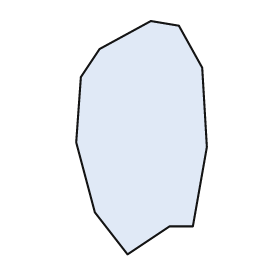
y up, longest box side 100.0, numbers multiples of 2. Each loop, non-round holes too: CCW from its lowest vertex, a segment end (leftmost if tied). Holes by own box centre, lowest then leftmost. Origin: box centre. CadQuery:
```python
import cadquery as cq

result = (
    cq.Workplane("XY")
    .moveTo(-6.0, -50.0)
    .lineTo(12.0, -38.0)
    .lineTo(22.0, -38.0)
    .lineTo(28.0, -4.0)
    .lineTo(26.0, 30.0)
    .lineTo(16.0, 48.0)
    .lineTo(4.0, 50.0)
    .lineTo(-18.0, 38.0)
    .lineTo(-26.0, 26.0)
    .lineTo(-28.0, -2.0)
    .lineTo(-20.0, -32.0)
    .close()
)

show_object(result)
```